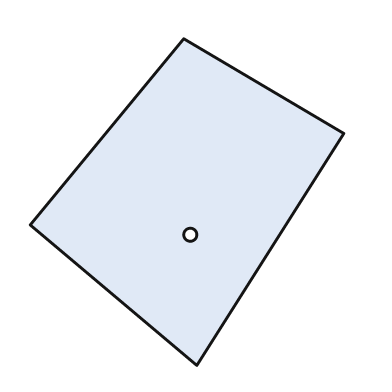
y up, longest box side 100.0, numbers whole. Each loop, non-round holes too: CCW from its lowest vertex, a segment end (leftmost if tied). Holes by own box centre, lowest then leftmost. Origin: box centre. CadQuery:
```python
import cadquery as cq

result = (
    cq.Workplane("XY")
    .moveTo(3.0, -50.0)
    .lineTo(48.0, 21.0)
    .lineTo(-1.0, 50.0)
    .lineTo(-48.0, -7.0)
    .close()
    .moveTo(1.0, -10.0)
    .circle(2.0)
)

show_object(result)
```